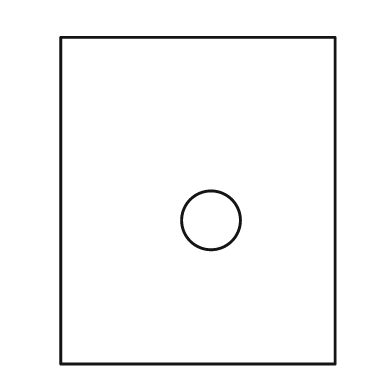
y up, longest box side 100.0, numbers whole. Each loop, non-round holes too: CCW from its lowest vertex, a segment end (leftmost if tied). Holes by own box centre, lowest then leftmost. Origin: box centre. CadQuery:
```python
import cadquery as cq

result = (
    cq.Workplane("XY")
    .moveTo(-42.0, -50.0)
    .lineTo(42.0, -50.0)
    .lineTo(42.0, 50.0)
    .lineTo(-42.0, 50.0)
    .close()
    .moveTo(4.0, -6.0)
    .circle(9.0)
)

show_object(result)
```